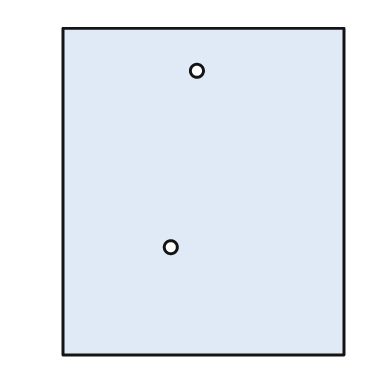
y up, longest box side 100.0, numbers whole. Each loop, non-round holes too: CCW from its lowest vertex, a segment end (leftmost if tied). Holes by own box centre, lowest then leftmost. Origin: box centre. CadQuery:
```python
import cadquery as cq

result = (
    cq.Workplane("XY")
    .moveTo(-43.0, -50.0)
    .lineTo(43.0, -50.0)
    .lineTo(43.0, 50.0)
    .lineTo(-43.0, 50.0)
    .close()
    .moveTo(-10.0, -17.0)
    .circle(2.0)
    .moveTo(-2.0, 37.0)
    .circle(2.0)
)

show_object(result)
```